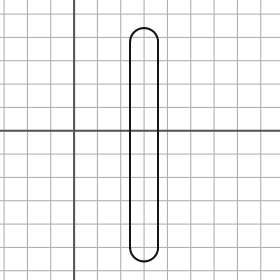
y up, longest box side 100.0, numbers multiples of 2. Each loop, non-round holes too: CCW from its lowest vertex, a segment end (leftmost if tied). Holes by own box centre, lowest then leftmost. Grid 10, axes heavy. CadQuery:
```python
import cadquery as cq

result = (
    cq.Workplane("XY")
    .moveTo(24.0, -50.0)
    .threePointArc((30.0, -56.0), (36.0, -50.0))
    .lineTo(36.0, 38.0)
    .threePointArc((30.0, 44.0), (24.0, 38.0))
    .close()
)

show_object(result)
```